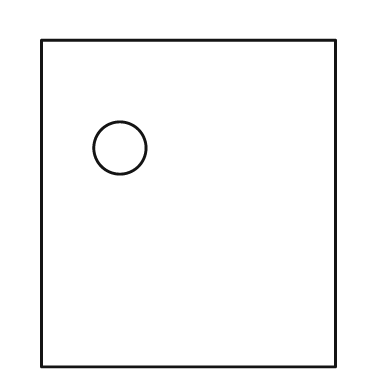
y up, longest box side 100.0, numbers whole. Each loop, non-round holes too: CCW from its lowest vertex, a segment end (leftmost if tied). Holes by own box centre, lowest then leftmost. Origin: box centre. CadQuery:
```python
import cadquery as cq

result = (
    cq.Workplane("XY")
    .moveTo(-45.0, -50.0)
    .lineTo(45.0, -50.0)
    .lineTo(45.0, 50.0)
    .lineTo(-45.0, 50.0)
    .close()
    .moveTo(-21.0, 17.0)
    .circle(8.0)
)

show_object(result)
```